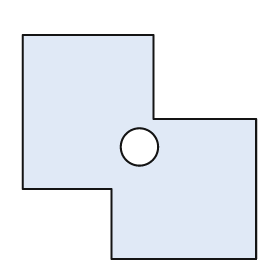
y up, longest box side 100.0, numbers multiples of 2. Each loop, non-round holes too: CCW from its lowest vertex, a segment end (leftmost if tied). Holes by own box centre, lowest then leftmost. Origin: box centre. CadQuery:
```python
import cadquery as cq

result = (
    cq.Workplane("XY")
    .moveTo(-12.0, -48.0)
    .lineTo(50.0, -48.0)
    .lineTo(50.0, 12.0)
    .lineTo(6.0, 12.0)
    .lineTo(6.0, 48.0)
    .lineTo(-50.0, 48.0)
    .lineTo(-50.0, -18.0)
    .lineTo(-12.0, -18.0)
    .close()
    .moveTo(0.0, 0.0)
    .circle(8.0)
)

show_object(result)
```